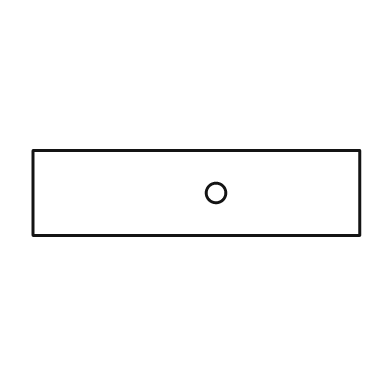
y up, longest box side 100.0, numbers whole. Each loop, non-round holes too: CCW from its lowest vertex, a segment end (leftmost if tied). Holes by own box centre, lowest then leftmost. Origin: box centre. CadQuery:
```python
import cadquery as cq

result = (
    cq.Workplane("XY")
    .moveTo(-50.0, -13.0)
    .lineTo(50.0, -13.0)
    .lineTo(50.0, 13.0)
    .lineTo(-50.0, 13.0)
    .close()
    .moveTo(6.0, 0.0)
    .circle(3.0)
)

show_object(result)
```